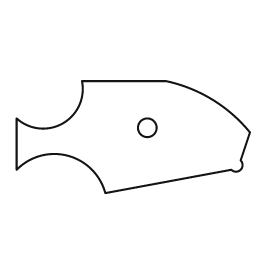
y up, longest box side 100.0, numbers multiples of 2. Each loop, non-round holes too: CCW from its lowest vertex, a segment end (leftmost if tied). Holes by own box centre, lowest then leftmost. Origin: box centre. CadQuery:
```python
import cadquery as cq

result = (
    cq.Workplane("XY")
    .moveTo(-12.0, -24.0)
    .lineTo(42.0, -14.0)
    .threePointArc((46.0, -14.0), (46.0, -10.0))
    .lineTo(50.0, 2.0)
    .threePointArc((34.0, 16.0), (14.0, 24.0))
    .lineTo(-22.0, 24.0)
    .threePointArc((-30.0, 6.0), (-50.0, 8.0))
    .lineTo(-50.0, -14.0)
    .threePointArc((-28.0, -8.0), (-12.0, -24.0))
    .close()
    .moveTo(6.0, 4.0)
    .circle(4.0)
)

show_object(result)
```